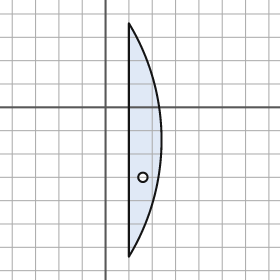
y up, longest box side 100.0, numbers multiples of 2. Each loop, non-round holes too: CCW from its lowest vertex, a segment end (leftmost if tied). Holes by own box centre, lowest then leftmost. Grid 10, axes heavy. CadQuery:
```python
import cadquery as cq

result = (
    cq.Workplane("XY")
    .moveTo(10.0, -64.0)
    .threePointArc((24.0, -14.0), (10.0, 36.0))
    .close()
    .moveTo(16.0, -30.0)
    .circle(2.0)
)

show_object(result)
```